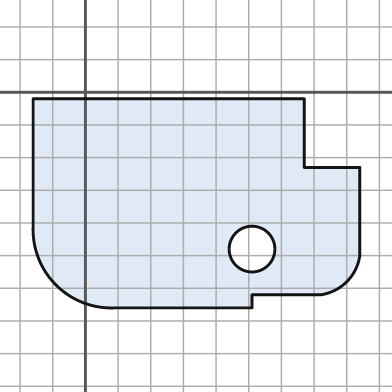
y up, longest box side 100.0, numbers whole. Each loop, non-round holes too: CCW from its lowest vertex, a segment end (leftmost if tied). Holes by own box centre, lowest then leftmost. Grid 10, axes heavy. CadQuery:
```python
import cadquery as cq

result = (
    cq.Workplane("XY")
    .moveTo(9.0, -66.0)
    .lineTo(51.0, -66.0)
    .lineTo(51.0, -62.0)
    .lineTo(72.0, -62.0)
    .threePointArc((80.0, -58.0), (84.0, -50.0))
    .lineTo(84.0, -23.0)
    .lineTo(67.0, -23.0)
    .lineTo(67.0, -2.0)
    .lineTo(-16.0, -2.0)
    .lineTo(-16.0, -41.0)
    .threePointArc((-9.0, -59.0), (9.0, -66.0))
    .close()
    .moveTo(51.0, -48.0)
    .circle(7.0)
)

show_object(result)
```